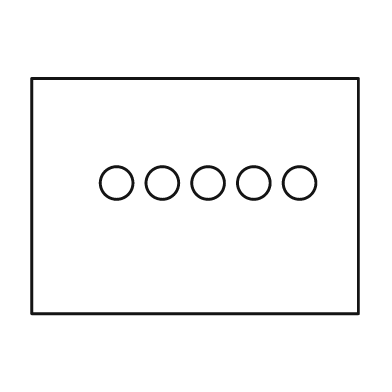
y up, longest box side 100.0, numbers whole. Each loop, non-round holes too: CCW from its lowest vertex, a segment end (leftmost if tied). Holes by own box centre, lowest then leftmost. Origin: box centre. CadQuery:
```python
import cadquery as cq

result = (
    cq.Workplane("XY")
    .moveTo(-50.0, -36.0)
    .lineTo(50.0, -36.0)
    .lineTo(50.0, 36.0)
    .lineTo(-50.0, 36.0)
    .close()
    .moveTo(-24.0, 4.0)
    .circle(5.0)
    .moveTo(-10.0, 4.0)
    .circle(5.0)
    .moveTo(4.0, 4.0)
    .circle(5.0)
    .moveTo(18.0, 4.0)
    .circle(5.0)
    .moveTo(32.0, 4.0)
    .circle(5.0)
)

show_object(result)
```